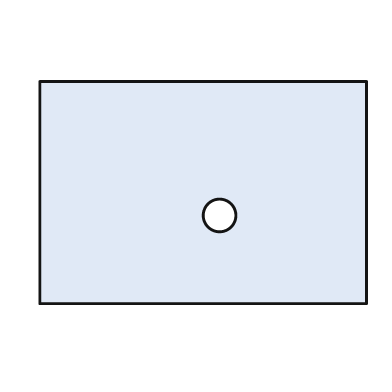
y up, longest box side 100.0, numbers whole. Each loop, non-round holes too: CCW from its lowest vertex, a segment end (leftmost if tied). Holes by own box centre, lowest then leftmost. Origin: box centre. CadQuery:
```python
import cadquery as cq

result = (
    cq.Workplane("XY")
    .moveTo(-50.0, -34.0)
    .lineTo(50.0, -34.0)
    .lineTo(50.0, 34.0)
    .lineTo(-50.0, 34.0)
    .close()
    .moveTo(5.0, -7.0)
    .circle(5.0)
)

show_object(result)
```